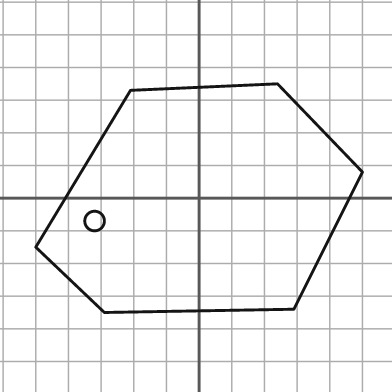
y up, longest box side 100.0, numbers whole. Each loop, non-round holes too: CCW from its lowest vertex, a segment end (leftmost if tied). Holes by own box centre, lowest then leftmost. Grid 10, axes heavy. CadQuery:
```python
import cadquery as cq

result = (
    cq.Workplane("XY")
    .moveTo(-29.0, -35.0)
    .lineTo(29.0, -34.0)
    .lineTo(50.0, 8.0)
    .lineTo(24.0, 35.0)
    .lineTo(-21.0, 33.0)
    .lineTo(-50.0, -15.0)
    .close()
    .moveTo(-32.0, -7.0)
    .circle(3.0)
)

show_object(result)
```